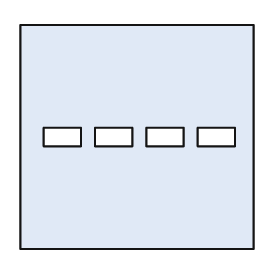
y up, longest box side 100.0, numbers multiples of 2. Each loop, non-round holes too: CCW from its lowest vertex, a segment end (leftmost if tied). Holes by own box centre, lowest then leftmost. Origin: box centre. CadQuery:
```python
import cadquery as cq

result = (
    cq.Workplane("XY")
    .moveTo(-50.0, -48.0)
    .lineTo(50.0, -48.0)
    .lineTo(50.0, 48.0)
    .lineTo(-50.0, 48.0)
    .close()
    .moveTo(-40.0, -4.0)
    .lineTo(-24.0, -4.0)
    .lineTo(-24.0, 4.0)
    .lineTo(-40.0, 4.0)
    .close()
    .moveTo(-18.0, -4.0)
    .lineTo(-2.0, -4.0)
    .lineTo(-2.0, 4.0)
    .lineTo(-18.0, 4.0)
    .close()
    .moveTo(4.0, -4.0)
    .lineTo(20.0, -4.0)
    .lineTo(20.0, 4.0)
    .lineTo(4.0, 4.0)
    .close()
    .moveTo(26.0, -4.0)
    .lineTo(42.0, -4.0)
    .lineTo(42.0, 4.0)
    .lineTo(26.0, 4.0)
    .close()
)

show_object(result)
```